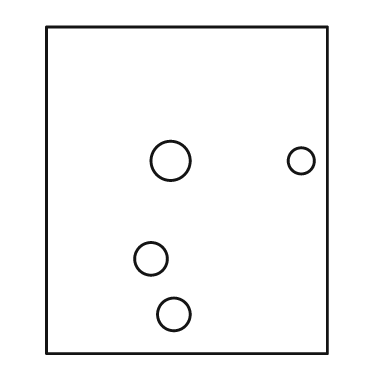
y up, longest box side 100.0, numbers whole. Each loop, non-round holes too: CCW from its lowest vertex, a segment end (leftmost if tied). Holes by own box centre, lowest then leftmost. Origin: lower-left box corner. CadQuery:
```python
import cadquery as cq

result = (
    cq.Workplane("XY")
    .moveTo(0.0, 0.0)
    .lineTo(86.0, 0.0)
    .lineTo(86.0, 100.0)
    .lineTo(0.0, 100.0)
    .close()
    .moveTo(39.0, 12.0)
    .circle(5.0)
    .moveTo(32.0, 29.0)
    .circle(5.0)
    .moveTo(38.0, 59.0)
    .circle(6.0)
    .moveTo(78.0, 59.0)
    .circle(4.0)
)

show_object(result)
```